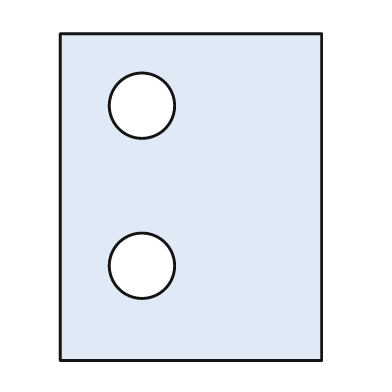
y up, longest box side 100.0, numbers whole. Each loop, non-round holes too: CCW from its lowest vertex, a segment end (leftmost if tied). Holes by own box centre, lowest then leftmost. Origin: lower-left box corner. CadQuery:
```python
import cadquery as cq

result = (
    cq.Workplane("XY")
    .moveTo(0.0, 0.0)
    .lineTo(80.0, 0.0)
    .lineTo(80.0, 100.0)
    .lineTo(0.0, 100.0)
    .close()
    .moveTo(25.0, 29.0)
    .circle(10.0)
    .moveTo(25.0, 78.0)
    .circle(10.0)
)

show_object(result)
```